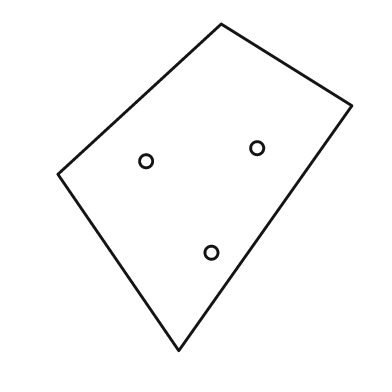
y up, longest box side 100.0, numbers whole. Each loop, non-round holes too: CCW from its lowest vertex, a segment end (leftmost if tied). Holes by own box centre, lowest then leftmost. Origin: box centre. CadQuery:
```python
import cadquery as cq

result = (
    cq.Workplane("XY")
    .moveTo(-8.0, -50.0)
    .lineTo(45.0, 25.0)
    .lineTo(5.0, 50.0)
    .lineTo(-45.0, 4.0)
    .close()
    .moveTo(2.0, -20.0)
    .circle(2.0)
    .moveTo(-18.0, 8.0)
    .circle(2.0)
    .moveTo(16.0, 12.0)
    .circle(2.0)
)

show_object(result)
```